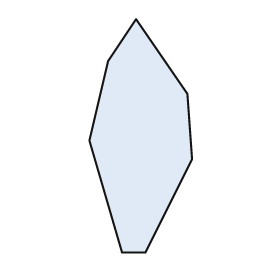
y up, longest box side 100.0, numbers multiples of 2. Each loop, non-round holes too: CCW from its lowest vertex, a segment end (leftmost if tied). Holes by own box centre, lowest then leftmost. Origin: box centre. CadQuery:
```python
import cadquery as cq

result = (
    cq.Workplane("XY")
    .moveTo(-8.0, -50.0)
    .lineTo(2.0, -50.0)
    .lineTo(22.0, -10.0)
    .lineTo(20.0, 18.0)
    .lineTo(-2.0, 50.0)
    .lineTo(-14.0, 32.0)
    .lineTo(-22.0, -2.0)
    .close()
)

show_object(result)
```